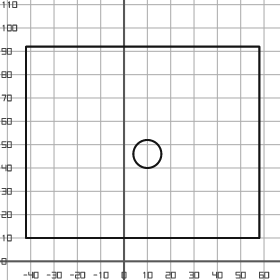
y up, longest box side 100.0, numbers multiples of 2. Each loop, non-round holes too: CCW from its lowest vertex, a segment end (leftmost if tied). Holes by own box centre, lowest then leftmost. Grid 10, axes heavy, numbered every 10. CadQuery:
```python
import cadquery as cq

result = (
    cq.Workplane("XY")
    .moveTo(-42.0, 10.0)
    .lineTo(58.0, 10.0)
    .lineTo(58.0, 92.0)
    .lineTo(-42.0, 92.0)
    .close()
    .moveTo(10.0, 46.0)
    .circle(6.0)
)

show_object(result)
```